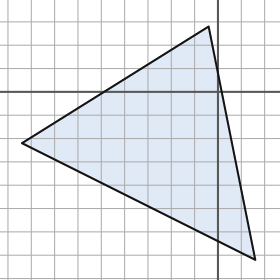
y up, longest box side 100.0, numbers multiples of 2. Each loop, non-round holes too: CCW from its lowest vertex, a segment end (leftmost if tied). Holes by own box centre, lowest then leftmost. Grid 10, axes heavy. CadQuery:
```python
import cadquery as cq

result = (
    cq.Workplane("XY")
    .moveTo(16.0, -72.0)
    .lineTo(-4.0, 28.0)
    .lineTo(-84.0, -22.0)
    .close()
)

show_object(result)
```